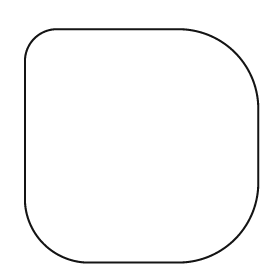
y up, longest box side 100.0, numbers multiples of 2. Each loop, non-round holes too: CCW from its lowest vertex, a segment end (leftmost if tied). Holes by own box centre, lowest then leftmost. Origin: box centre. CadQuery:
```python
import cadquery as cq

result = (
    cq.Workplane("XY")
    .moveTo(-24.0, -50.0)
    .lineTo(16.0, -50.0)
    .threePointArc((40.0, -40.0), (50.0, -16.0))
    .lineTo(50.0, 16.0)
    .threePointArc((40.0, 40.0), (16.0, 50.0))
    .lineTo(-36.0, 50.0)
    .threePointArc((-46.0, 46.0), (-50.0, 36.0))
    .lineTo(-50.0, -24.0)
    .threePointArc((-42.0, -42.0), (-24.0, -50.0))
    .close()
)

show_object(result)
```